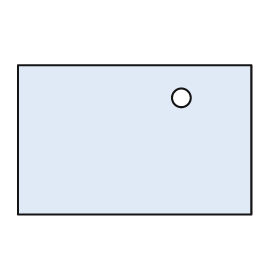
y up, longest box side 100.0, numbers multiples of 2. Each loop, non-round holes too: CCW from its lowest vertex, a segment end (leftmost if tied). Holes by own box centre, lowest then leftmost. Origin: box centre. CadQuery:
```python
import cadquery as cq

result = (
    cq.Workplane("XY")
    .moveTo(-50.0, -32.0)
    .lineTo(50.0, -32.0)
    .lineTo(50.0, 32.0)
    .lineTo(-50.0, 32.0)
    .close()
    .moveTo(20.0, 18.0)
    .circle(4.0)
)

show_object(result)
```